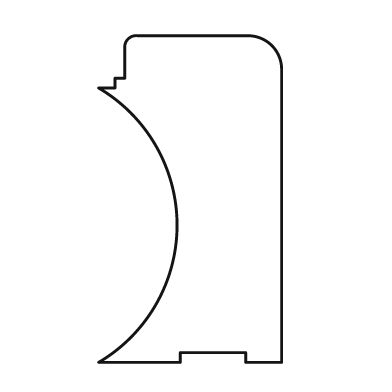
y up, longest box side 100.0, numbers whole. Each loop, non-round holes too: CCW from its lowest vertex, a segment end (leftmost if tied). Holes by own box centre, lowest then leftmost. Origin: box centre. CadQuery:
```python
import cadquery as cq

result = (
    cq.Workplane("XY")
    .moveTo(-28.0, -50.0)
    .lineTo(-3.0, -50.0)
    .lineTo(-3.0, -47.0)
    .lineTo(17.0, -47.0)
    .lineTo(17.0, -50.0)
    .lineTo(28.0, -50.0)
    .lineTo(28.0, 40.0)
    .threePointArc((25.0, 47.0), (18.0, 50.0))
    .lineTo(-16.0, 50.0)
    .threePointArc((-19.0, 49.0), (-20.0, 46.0))
    .lineTo(-20.0, 37.0)
    .lineTo(-23.0, 37.0)
    .lineTo(-23.0, 34.0)
    .lineTo(-28.0, 34.0)
    .threePointArc((-4.0, -8.0), (-28.0, -50.0))
    .close()
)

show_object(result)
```